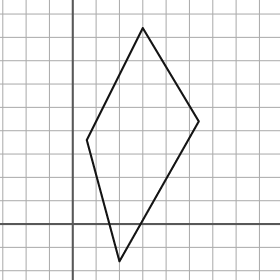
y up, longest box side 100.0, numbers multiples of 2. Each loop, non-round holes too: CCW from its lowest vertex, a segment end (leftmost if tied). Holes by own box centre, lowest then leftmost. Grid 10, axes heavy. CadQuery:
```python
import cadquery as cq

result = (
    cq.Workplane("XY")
    .moveTo(20.0, -16.0)
    .lineTo(54.0, 44.0)
    .lineTo(30.0, 84.0)
    .lineTo(6.0, 36.0)
    .close()
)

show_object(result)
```